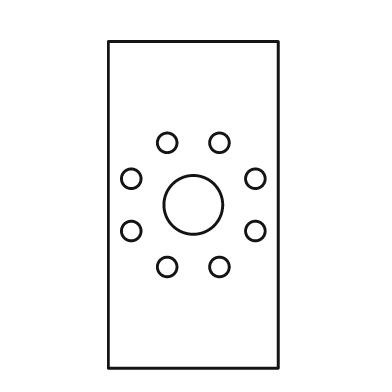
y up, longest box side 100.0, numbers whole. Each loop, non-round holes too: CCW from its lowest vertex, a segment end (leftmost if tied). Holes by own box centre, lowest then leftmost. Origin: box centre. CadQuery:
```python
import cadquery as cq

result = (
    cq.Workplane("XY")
    .moveTo(-26.0, -50.0)
    .lineTo(26.0, -50.0)
    .lineTo(26.0, 50.0)
    .lineTo(-26.0, 50.0)
    .close()
    .moveTo(-8.0, -19.0)
    .circle(3.0)
    .moveTo(8.0, -19.0)
    .circle(3.0)
    .moveTo(-19.0, -8.0)
    .circle(3.0)
    .moveTo(19.0, -8.0)
    .circle(3.0)
    .moveTo(0.0, 0.0)
    .circle(9.0)
    .moveTo(-19.0, 8.0)
    .circle(3.0)
    .moveTo(19.0, 8.0)
    .circle(3.0)
    .moveTo(-8.0, 19.0)
    .circle(3.0)
    .moveTo(8.0, 19.0)
    .circle(3.0)
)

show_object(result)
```